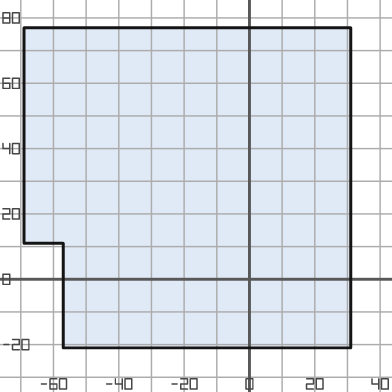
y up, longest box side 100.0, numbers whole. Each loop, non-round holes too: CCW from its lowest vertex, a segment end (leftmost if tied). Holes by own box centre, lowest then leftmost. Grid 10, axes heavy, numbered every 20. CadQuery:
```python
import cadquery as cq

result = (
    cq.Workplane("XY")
    .moveTo(-57.0, -21.0)
    .lineTo(31.0, -21.0)
    .lineTo(31.0, 77.0)
    .lineTo(-69.0, 77.0)
    .lineTo(-69.0, 11.0)
    .lineTo(-57.0, 11.0)
    .close()
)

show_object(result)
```